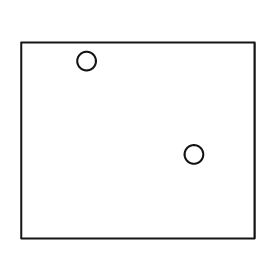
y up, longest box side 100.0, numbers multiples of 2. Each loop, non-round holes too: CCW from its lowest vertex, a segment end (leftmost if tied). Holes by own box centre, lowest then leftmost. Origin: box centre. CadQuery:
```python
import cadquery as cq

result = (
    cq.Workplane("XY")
    .moveTo(-50.0, -42.0)
    .lineTo(50.0, -42.0)
    .lineTo(50.0, 42.0)
    .lineTo(-50.0, 42.0)
    .close()
    .moveTo(24.0, -6.0)
    .circle(4.0)
    .moveTo(-22.0, 34.0)
    .circle(4.0)
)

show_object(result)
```